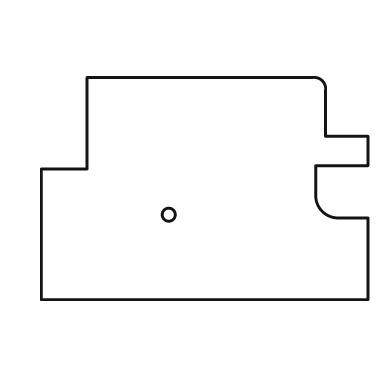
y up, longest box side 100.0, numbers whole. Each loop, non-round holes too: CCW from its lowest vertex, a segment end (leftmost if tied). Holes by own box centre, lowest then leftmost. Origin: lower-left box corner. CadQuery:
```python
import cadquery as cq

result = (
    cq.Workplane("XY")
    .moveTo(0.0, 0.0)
    .lineTo(100.0, 0.0)
    .lineTo(100.0, 25.0)
    .lineTo(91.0, 25.0)
    .threePointArc((86.0, 27.0), (84.0, 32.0))
    .lineTo(84.0, 41.0)
    .lineTo(100.0, 41.0)
    .lineTo(100.0, 50.0)
    .lineTo(87.0, 50.0)
    .lineTo(87.0, 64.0)
    .threePointArc((86.0, 67.0), (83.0, 68.0))
    .lineTo(14.0, 68.0)
    .lineTo(14.0, 40.0)
    .lineTo(0.0, 40.0)
    .close()
    .moveTo(39.0, 26.0)
    .circle(2.0)
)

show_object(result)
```